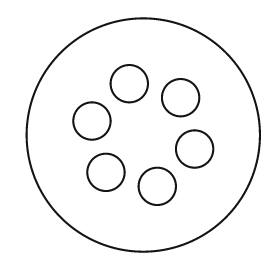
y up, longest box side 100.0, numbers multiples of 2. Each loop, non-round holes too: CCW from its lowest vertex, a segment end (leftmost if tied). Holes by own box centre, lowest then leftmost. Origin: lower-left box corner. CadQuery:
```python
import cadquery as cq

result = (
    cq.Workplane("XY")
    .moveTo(50.0, 50.0)
    .circle(50.0)
    .moveTo(56.0, 28.0)
    .circle(8.0)
    .moveTo(34.0, 34.0)
    .circle(8.0)
    .moveTo(72.0, 44.0)
    .circle(8.0)
    .moveTo(28.0, 56.0)
    .circle(8.0)
    .moveTo(66.0, 66.0)
    .circle(8.0)
    .moveTo(44.0, 72.0)
    .circle(8.0)
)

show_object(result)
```